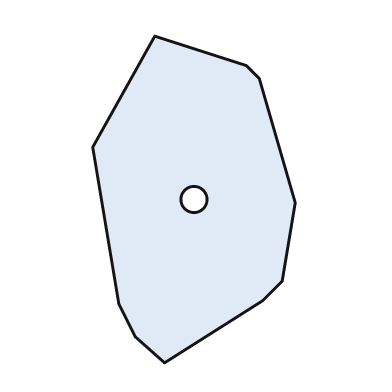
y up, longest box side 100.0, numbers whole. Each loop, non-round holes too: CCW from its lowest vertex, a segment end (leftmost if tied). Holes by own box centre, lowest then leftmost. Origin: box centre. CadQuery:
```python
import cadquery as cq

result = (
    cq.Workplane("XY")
    .moveTo(-9.0, -50.0)
    .lineTo(21.0, -31.0)
    .lineTo(27.0, -25.0)
    .lineTo(31.0, -1.0)
    .lineTo(20.0, 37.0)
    .lineTo(16.0, 41.0)
    .lineTo(-12.0, 50.0)
    .lineTo(-31.0, 16.0)
    .lineTo(-23.0, -32.0)
    .lineTo(-18.0, -42.0)
    .close()
    .moveTo(0.0, 0.0)
    .circle(4.0)
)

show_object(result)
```